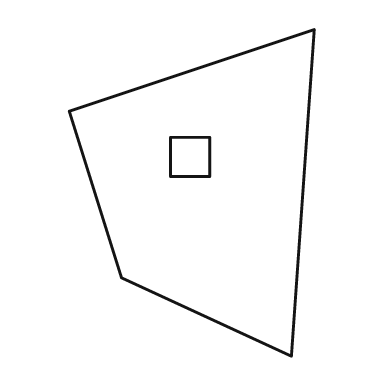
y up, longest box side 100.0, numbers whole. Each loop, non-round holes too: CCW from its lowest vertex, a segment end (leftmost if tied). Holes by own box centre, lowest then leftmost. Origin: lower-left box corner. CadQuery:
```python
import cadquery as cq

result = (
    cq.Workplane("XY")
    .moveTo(68.0, 0.0)
    .lineTo(75.0, 100.0)
    .lineTo(0.0, 75.0)
    .lineTo(16.0, 24.0)
    .close()
    .moveTo(31.0, 55.0)
    .lineTo(43.0, 55.0)
    .lineTo(43.0, 67.0)
    .lineTo(31.0, 67.0)
    .close()
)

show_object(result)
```